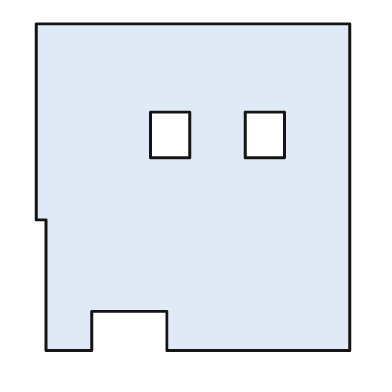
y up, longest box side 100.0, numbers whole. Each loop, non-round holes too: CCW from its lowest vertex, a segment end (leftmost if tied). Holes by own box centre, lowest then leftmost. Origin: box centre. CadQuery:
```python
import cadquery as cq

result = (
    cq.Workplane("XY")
    .moveTo(-45.0, -50.0)
    .lineTo(-31.0, -50.0)
    .lineTo(-31.0, -38.0)
    .lineTo(-8.0, -38.0)
    .lineTo(-8.0, -50.0)
    .lineTo(48.0, -50.0)
    .lineTo(48.0, 50.0)
    .lineTo(-48.0, 50.0)
    .lineTo(-48.0, -10.0)
    .lineTo(-45.0, -10.0)
    .close()
    .moveTo(-13.0, 9.0)
    .lineTo(-1.0, 9.0)
    .lineTo(-1.0, 23.0)
    .lineTo(-13.0, 23.0)
    .close()
    .moveTo(16.0, 9.0)
    .lineTo(28.0, 9.0)
    .lineTo(28.0, 23.0)
    .lineTo(16.0, 23.0)
    .close()
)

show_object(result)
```